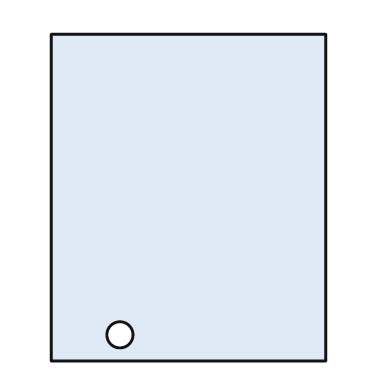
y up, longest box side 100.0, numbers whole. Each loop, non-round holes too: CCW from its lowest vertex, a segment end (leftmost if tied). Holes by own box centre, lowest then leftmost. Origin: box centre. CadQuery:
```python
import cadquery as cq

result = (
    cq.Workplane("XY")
    .moveTo(-42.0, -50.0)
    .lineTo(42.0, -50.0)
    .lineTo(42.0, 50.0)
    .lineTo(-42.0, 50.0)
    .close()
    .moveTo(-21.0, -42.0)
    .circle(4.0)
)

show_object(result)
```